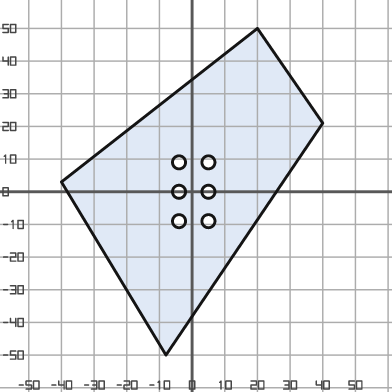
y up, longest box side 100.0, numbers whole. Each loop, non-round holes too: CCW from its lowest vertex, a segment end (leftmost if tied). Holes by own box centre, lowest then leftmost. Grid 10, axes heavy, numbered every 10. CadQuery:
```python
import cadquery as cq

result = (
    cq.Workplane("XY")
    .moveTo(-8.0, -50.0)
    .lineTo(40.0, 21.0)
    .lineTo(20.0, 50.0)
    .lineTo(-40.0, 3.0)
    .close()
    .moveTo(-4.0, -9.0)
    .circle(2.0)
    .moveTo(5.0, -9.0)
    .circle(2.0)
    .moveTo(-4.0, 0.0)
    .circle(2.0)
    .moveTo(5.0, 0.0)
    .circle(2.0)
    .moveTo(-4.0, 9.0)
    .circle(2.0)
    .moveTo(5.0, 9.0)
    .circle(2.0)
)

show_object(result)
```